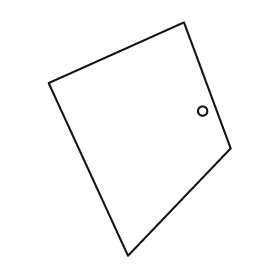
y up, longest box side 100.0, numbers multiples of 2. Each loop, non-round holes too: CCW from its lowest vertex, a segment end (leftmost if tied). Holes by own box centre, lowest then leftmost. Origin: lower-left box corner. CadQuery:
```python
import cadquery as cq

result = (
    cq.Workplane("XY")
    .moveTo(34.0, 0.0)
    .lineTo(78.0, 46.0)
    .lineTo(58.0, 100.0)
    .lineTo(0.0, 74.0)
    .close()
    .moveTo(66.0, 62.0)
    .circle(2.0)
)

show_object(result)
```